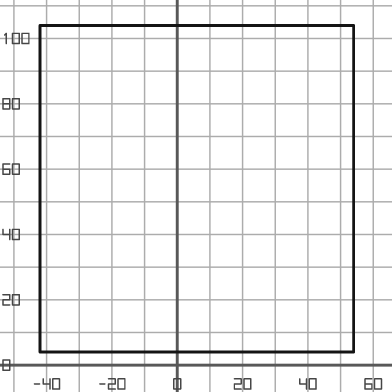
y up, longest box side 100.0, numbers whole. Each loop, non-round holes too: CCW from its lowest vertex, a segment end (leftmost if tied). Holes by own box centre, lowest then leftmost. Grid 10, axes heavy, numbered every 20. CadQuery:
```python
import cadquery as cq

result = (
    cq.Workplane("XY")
    .moveTo(-42.0, 4.0)
    .lineTo(54.0, 4.0)
    .lineTo(54.0, 104.0)
    .lineTo(-42.0, 104.0)
    .close()
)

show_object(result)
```